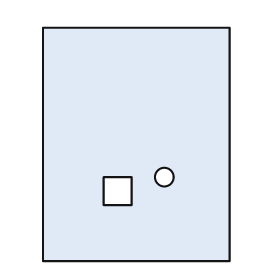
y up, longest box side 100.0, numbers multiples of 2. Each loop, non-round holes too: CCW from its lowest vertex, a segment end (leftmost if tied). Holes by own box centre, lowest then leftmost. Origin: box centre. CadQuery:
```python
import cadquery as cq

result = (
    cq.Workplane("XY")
    .moveTo(-40.0, -50.0)
    .lineTo(40.0, -50.0)
    .lineTo(40.0, 50.0)
    .lineTo(-40.0, 50.0)
    .close()
    .moveTo(-14.0, -26.0)
    .lineTo(-2.0, -26.0)
    .lineTo(-2.0, -14.0)
    .lineTo(-14.0, -14.0)
    .close()
    .moveTo(12.0, -14.0)
    .circle(4.0)
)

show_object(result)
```